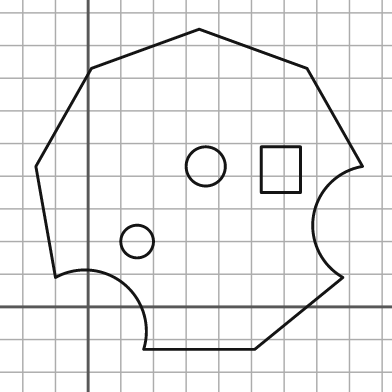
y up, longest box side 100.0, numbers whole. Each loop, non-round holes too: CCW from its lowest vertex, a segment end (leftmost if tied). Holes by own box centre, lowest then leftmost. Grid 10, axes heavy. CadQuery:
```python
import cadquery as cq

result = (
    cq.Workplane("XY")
    .moveTo(17.0, -13.0)
    .lineTo(51.0, -13.0)
    .lineTo(78.0, 9.0)
    .threePointArc((69.0, 28.0), (84.0, 43.0))
    .lineTo(67.0, 73.0)
    .lineTo(34.0, 85.0)
    .lineTo(1.0, 73.0)
    .lineTo(-16.0, 43.0)
    .lineTo(-10.0, 9.0)
    .threePointArc((11.0, 7.0), (17.0, -13.0))
    .close()
    .moveTo(15.0, 20.0)
    .circle(5.0)
    .moveTo(53.0, 35.0)
    .lineTo(65.0, 35.0)
    .lineTo(65.0, 49.0)
    .lineTo(53.0, 49.0)
    .close()
    .moveTo(36.0, 43.0)
    .circle(6.0)
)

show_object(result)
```